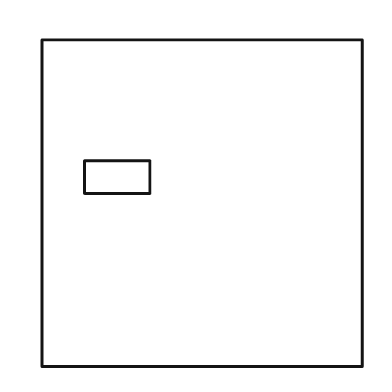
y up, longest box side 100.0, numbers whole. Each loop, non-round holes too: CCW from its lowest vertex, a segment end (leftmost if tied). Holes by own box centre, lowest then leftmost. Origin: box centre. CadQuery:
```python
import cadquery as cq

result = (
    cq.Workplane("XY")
    .moveTo(-49.0, -50.0)
    .lineTo(49.0, -50.0)
    .lineTo(49.0, 50.0)
    .lineTo(-49.0, 50.0)
    .close()
    .moveTo(-36.0, 3.0)
    .lineTo(-16.0, 3.0)
    .lineTo(-16.0, 13.0)
    .lineTo(-36.0, 13.0)
    .close()
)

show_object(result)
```